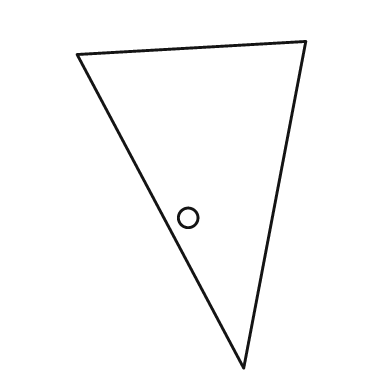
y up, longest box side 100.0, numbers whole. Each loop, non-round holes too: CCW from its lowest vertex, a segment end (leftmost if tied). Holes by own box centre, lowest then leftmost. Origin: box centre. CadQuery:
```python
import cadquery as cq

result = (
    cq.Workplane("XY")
    .moveTo(16.0, -50.0)
    .lineTo(35.0, 50.0)
    .lineTo(-35.0, 46.0)
    .close()
    .moveTo(-1.0, -4.0)
    .circle(3.0)
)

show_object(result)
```